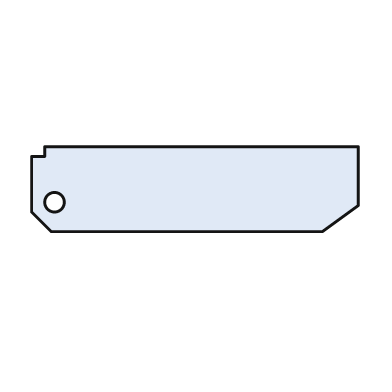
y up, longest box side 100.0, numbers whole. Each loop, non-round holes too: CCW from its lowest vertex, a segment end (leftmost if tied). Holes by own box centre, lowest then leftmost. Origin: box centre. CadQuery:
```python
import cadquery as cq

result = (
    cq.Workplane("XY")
    .moveTo(-44.0, -13.0)
    .lineTo(39.0, -13.0)
    .lineTo(50.0, -5.0)
    .lineTo(50.0, 13.0)
    .lineTo(-46.0, 13.0)
    .lineTo(-46.0, 10.0)
    .lineTo(-50.0, 10.0)
    .lineTo(-50.0, -7.0)
    .close()
    .moveTo(-43.0, -4.0)
    .circle(3.0)
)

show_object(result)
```